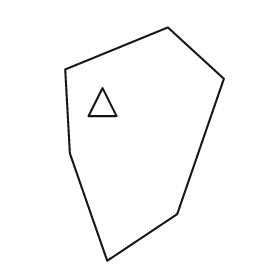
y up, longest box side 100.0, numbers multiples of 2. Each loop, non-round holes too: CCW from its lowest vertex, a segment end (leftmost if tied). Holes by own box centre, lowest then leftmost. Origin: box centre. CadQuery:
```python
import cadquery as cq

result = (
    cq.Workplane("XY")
    .moveTo(-16.0, -50.0)
    .lineTo(14.0, -30.0)
    .lineTo(34.0, 28.0)
    .lineTo(10.0, 50.0)
    .lineTo(-34.0, 32.0)
    .lineTo(-32.0, -4.0)
    .close()
    .moveTo(-24.0, 12.0)
    .lineTo(-12.0, 12.0)
    .lineTo(-18.0, 24.0)
    .close()
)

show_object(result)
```